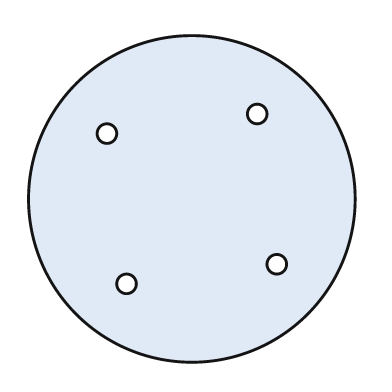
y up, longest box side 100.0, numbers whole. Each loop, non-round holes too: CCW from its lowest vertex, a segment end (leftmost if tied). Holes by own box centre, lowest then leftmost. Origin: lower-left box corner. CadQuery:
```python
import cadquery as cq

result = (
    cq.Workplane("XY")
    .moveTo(50.0, 50.0)
    .circle(50.0)
    .moveTo(30.0, 24.0)
    .circle(3.0)
    .moveTo(76.0, 30.0)
    .circle(3.0)
    .moveTo(24.0, 70.0)
    .circle(3.0)
    .moveTo(70.0, 76.0)
    .circle(3.0)
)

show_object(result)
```